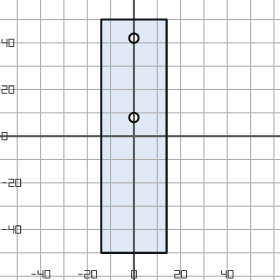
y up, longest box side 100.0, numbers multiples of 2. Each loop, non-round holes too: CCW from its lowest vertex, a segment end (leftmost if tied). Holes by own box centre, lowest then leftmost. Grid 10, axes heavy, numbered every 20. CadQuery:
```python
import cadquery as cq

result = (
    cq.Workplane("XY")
    .moveTo(-14.0, -50.0)
    .lineTo(14.0, -50.0)
    .lineTo(14.0, 50.0)
    .lineTo(-14.0, 50.0)
    .close()
    .moveTo(0.0, 8.0)
    .circle(2.0)
    .moveTo(0.0, 42.0)
    .circle(2.0)
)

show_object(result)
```